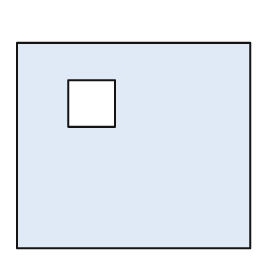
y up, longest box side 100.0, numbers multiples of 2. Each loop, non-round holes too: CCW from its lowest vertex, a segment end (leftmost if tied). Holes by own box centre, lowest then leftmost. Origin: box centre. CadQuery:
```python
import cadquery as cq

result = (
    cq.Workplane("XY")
    .moveTo(-50.0, -44.0)
    .lineTo(50.0, -44.0)
    .lineTo(50.0, 44.0)
    .lineTo(-50.0, 44.0)
    .close()
    .moveTo(-28.0, 8.0)
    .lineTo(-8.0, 8.0)
    .lineTo(-8.0, 28.0)
    .lineTo(-28.0, 28.0)
    .close()
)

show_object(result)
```